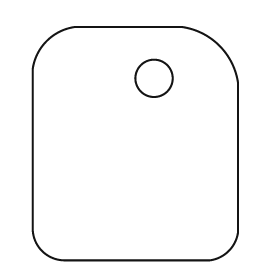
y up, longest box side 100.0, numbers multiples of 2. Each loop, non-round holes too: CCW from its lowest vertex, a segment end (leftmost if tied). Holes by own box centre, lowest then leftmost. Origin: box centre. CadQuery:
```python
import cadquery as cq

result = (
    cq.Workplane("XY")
    .moveTo(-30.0, -50.0)
    .lineTo(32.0, -50.0)
    .threePointArc((40.0, -46.0), (44.0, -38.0))
    .lineTo(44.0, 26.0)
    .threePointArc((36.0, 42.0), (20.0, 50.0))
    .lineTo(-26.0, 50.0)
    .threePointArc((-38.0, 44.0), (-44.0, 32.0))
    .lineTo(-44.0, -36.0)
    .threePointArc((-40.0, -46.0), (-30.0, -50.0))
    .close()
    .moveTo(8.0, 28.0)
    .circle(8.0)
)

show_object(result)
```